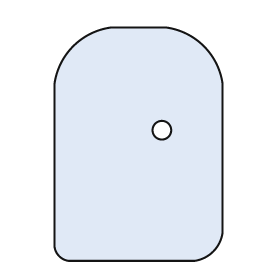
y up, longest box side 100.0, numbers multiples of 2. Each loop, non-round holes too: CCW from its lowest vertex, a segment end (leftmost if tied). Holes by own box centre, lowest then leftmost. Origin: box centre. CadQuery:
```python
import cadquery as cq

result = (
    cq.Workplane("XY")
    .moveTo(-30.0, -50.0)
    .lineTo(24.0, -50.0)
    .threePointArc((32.0, -46.0), (36.0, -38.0))
    .lineTo(36.0, 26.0)
    .threePointArc((28.0, 42.0), (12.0, 50.0))
    .lineTo(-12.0, 50.0)
    .threePointArc((-28.0, 42.0), (-36.0, 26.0))
    .lineTo(-36.0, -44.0)
    .threePointArc((-34.0, -48.0), (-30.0, -50.0))
    .close()
    .moveTo(10.0, 6.0)
    .circle(4.0)
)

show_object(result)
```